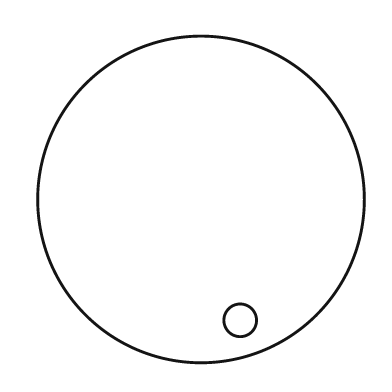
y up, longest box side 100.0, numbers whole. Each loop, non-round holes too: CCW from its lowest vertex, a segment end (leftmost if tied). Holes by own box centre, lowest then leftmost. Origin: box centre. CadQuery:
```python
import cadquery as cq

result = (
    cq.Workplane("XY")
    .moveTo(0.0, 0.0)
    .circle(50.0)
    .moveTo(12.0, -37.0)
    .circle(5.0)
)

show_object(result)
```